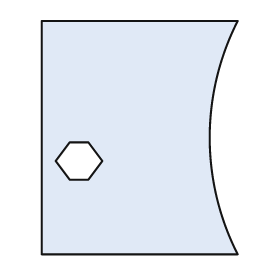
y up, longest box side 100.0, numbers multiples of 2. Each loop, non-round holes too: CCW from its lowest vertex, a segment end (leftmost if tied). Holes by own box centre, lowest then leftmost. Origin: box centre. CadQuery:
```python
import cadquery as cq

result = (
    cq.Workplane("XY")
    .moveTo(-42.0, -50.0)
    .lineTo(42.0, -50.0)
    .threePointArc((30.0, 0.0), (42.0, 50.0))
    .lineTo(-42.0, 50.0)
    .close()
    .moveTo(-30.0, -18.0)
    .lineTo(-22.0, -18.0)
    .lineTo(-16.0, -10.0)
    .lineTo(-22.0, -2.0)
    .lineTo(-30.0, -2.0)
    .lineTo(-36.0, -10.0)
    .close()
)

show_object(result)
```